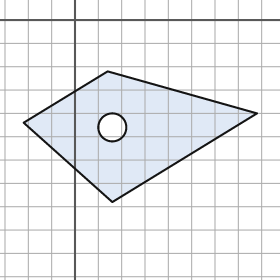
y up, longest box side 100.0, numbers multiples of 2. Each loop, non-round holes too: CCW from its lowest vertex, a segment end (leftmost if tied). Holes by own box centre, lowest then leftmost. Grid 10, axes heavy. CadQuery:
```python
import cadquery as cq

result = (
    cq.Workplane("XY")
    .moveTo(16.0, -78.0)
    .lineTo(78.0, -40.0)
    .lineTo(14.0, -22.0)
    .lineTo(-22.0, -44.0)
    .close()
    .moveTo(16.0, -46.0)
    .circle(6.0)
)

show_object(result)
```